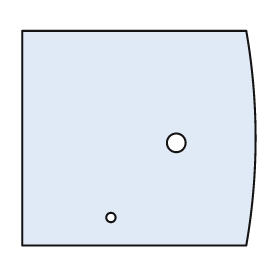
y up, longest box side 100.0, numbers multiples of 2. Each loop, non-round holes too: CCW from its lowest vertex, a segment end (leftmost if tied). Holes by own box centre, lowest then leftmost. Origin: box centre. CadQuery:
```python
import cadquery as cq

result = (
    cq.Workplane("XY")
    .moveTo(-50.0, -46.0)
    .lineTo(46.0, -46.0)
    .threePointArc((50.0, 0.0), (46.0, 46.0))
    .lineTo(-50.0, 46.0)
    .close()
    .moveTo(-12.0, -34.0)
    .circle(2.0)
    .moveTo(16.0, -2.0)
    .circle(4.0)
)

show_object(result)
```